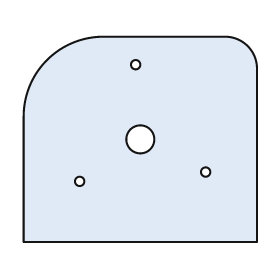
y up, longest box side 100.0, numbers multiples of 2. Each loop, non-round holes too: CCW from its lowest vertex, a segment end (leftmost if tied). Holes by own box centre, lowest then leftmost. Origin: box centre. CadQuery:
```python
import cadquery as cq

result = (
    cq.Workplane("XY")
    .moveTo(-50.0, -44.0)
    .lineTo(50.0, -44.0)
    .lineTo(50.0, 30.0)
    .threePointArc((46.0, 40.0), (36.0, 44.0))
    .lineTo(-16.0, 44.0)
    .threePointArc((-40.0, 34.0), (-50.0, 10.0))
    .close()
    .moveTo(-26.0, -18.0)
    .circle(2.0)
    .moveTo(28.0, -14.0)
    .circle(2.0)
    .moveTo(0.0, 0.0)
    .circle(6.0)
    .moveTo(-2.0, 32.0)
    .circle(2.0)
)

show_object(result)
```